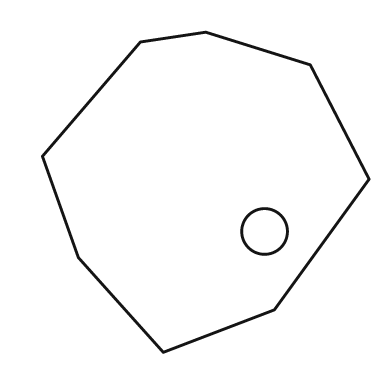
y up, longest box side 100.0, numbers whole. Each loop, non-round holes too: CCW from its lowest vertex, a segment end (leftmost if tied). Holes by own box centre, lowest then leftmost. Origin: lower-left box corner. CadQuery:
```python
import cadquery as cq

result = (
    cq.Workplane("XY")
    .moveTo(37.0, 0.0)
    .lineTo(71.0, 13.0)
    .lineTo(100.0, 53.0)
    .lineTo(82.0, 88.0)
    .lineTo(50.0, 98.0)
    .lineTo(30.0, 95.0)
    .lineTo(0.0, 60.0)
    .lineTo(11.0, 29.0)
    .close()
    .moveTo(68.0, 37.0)
    .circle(7.0)
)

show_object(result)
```